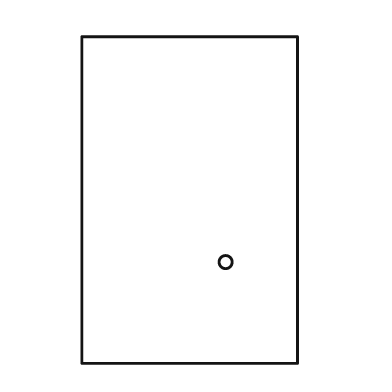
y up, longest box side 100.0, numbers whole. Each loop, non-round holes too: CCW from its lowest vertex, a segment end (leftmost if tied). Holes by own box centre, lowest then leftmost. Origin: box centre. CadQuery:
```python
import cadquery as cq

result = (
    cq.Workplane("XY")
    .moveTo(-33.0, -50.0)
    .lineTo(33.0, -50.0)
    .lineTo(33.0, 50.0)
    .lineTo(-33.0, 50.0)
    .close()
    .moveTo(11.0, -19.0)
    .circle(2.0)
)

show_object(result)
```